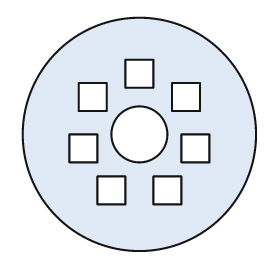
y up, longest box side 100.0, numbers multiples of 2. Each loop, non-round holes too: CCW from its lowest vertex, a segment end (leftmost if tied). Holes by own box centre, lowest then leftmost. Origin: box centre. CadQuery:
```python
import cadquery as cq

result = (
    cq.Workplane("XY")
    .moveTo(0.0, 0.0)
    .circle(50.0)
    .moveTo(-18.0, -30.0)
    .lineTo(-6.0, -30.0)
    .lineTo(-6.0, -18.0)
    .lineTo(-18.0, -18.0)
    .close()
    .moveTo(6.0, -30.0)
    .lineTo(18.0, -30.0)
    .lineTo(18.0, -18.0)
    .lineTo(6.0, -18.0)
    .close()
    .moveTo(-30.0, -12.0)
    .lineTo(-18.0, -12.0)
    .lineTo(-18.0, 0.0)
    .lineTo(-30.0, 0.0)
    .close()
    .moveTo(18.0, -12.0)
    .lineTo(30.0, -12.0)
    .lineTo(30.0, 0.0)
    .lineTo(18.0, 0.0)
    .close()
    .moveTo(0.0, 0.0)
    .circle(12.0)
    .moveTo(-26.0, 10.0)
    .lineTo(-14.0, 10.0)
    .lineTo(-14.0, 22.0)
    .lineTo(-26.0, 22.0)
    .close()
    .moveTo(14.0, 10.0)
    .lineTo(26.0, 10.0)
    .lineTo(26.0, 22.0)
    .lineTo(14.0, 22.0)
    .close()
    .moveTo(-6.0, 20.0)
    .lineTo(6.0, 20.0)
    .lineTo(6.0, 32.0)
    .lineTo(-6.0, 32.0)
    .close()
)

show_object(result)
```